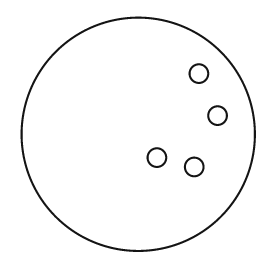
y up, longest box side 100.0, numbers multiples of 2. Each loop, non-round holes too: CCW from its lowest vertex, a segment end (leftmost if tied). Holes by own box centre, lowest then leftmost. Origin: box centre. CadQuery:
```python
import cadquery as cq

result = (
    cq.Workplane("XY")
    .moveTo(0.0, 0.0)
    .circle(50.0)
    .moveTo(24.0, -14.0)
    .circle(4.0)
    .moveTo(8.0, -10.0)
    .circle(4.0)
    .moveTo(34.0, 8.0)
    .circle(4.0)
    .moveTo(26.0, 26.0)
    .circle(4.0)
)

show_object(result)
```